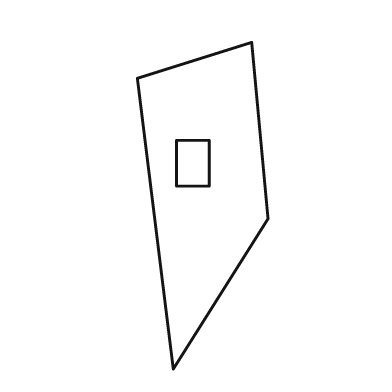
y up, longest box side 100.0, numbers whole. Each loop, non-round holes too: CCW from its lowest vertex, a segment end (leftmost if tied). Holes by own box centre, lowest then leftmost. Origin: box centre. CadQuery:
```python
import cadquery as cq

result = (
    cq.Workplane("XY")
    .moveTo(-9.0, -50.0)
    .lineTo(20.0, -4.0)
    .lineTo(15.0, 50.0)
    .lineTo(-20.0, 39.0)
    .close()
    .moveTo(-8.0, 6.0)
    .lineTo(2.0, 6.0)
    .lineTo(2.0, 20.0)
    .lineTo(-8.0, 20.0)
    .close()
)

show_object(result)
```